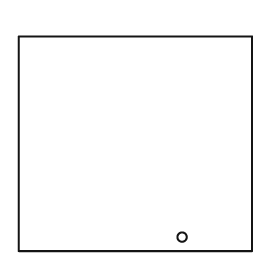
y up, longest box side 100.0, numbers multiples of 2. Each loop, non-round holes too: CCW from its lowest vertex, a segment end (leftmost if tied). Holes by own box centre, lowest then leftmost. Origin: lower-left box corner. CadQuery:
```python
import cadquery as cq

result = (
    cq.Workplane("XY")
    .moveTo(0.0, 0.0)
    .lineTo(100.0, 0.0)
    .lineTo(100.0, 92.0)
    .lineTo(0.0, 92.0)
    .close()
    .moveTo(70.0, 6.0)
    .circle(2.0)
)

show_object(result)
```